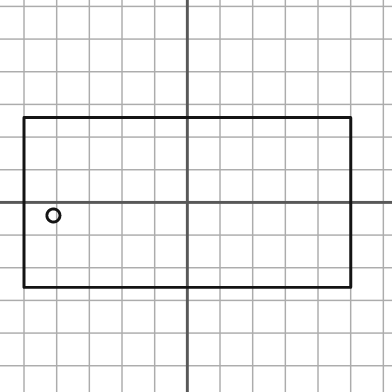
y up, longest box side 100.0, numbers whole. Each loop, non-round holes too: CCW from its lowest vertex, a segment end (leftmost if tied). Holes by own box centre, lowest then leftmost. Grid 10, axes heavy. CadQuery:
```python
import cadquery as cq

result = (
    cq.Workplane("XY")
    .moveTo(-50.0, -26.0)
    .lineTo(50.0, -26.0)
    .lineTo(50.0, 26.0)
    .lineTo(-50.0, 26.0)
    .close()
    .moveTo(-41.0, -4.0)
    .circle(2.0)
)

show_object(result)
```